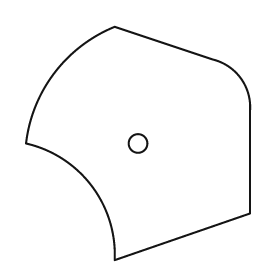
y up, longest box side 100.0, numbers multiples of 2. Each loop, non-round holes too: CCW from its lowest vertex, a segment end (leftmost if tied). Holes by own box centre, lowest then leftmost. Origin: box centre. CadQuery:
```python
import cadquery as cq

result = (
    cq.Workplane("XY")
    .moveTo(-10.0, -50.0)
    .lineTo(48.0, -30.0)
    .lineTo(48.0, 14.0)
    .threePointArc((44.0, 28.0), (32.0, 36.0))
    .lineTo(-10.0, 50.0)
    .threePointArc((-36.0, 30.0), (-48.0, 0.0))
    .threePointArc((-20.0, -18.0), (-10.0, -50.0))
    .close()
    .moveTo(0.0, 0.0)
    .circle(4.0)
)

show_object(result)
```